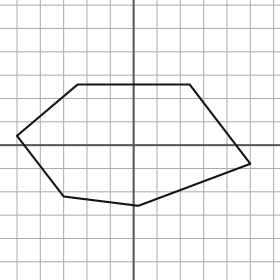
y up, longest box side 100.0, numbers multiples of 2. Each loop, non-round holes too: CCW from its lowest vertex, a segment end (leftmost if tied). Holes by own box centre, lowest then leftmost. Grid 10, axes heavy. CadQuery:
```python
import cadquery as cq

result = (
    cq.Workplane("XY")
    .moveTo(2.0, -26.0)
    .lineTo(50.0, -8.0)
    .lineTo(24.0, 26.0)
    .lineTo(-24.0, 26.0)
    .lineTo(-50.0, 4.0)
    .lineTo(-30.0, -22.0)
    .close()
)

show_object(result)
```